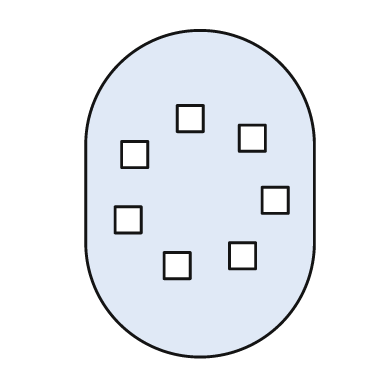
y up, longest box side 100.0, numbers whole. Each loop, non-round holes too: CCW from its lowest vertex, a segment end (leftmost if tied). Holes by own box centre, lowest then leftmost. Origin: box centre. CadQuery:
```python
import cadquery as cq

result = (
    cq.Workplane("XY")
    .moveTo(-35.0, -15.0)
    .threePointArc((0.0, -50.0), (35.0, -15.0))
    .lineTo(35.0, 15.0)
    .threePointArc((0.0, 50.0), (-35.0, 15.0))
    .close()
    .moveTo(-11.0, -26.0)
    .lineTo(-3.0, -26.0)
    .lineTo(-3.0, -18.0)
    .lineTo(-11.0, -18.0)
    .close()
    .moveTo(9.0, -23.0)
    .lineTo(17.0, -23.0)
    .lineTo(17.0, -15.0)
    .lineTo(9.0, -15.0)
    .close()
    .moveTo(-26.0, -12.0)
    .lineTo(-18.0, -12.0)
    .lineTo(-18.0, -4.0)
    .lineTo(-26.0, -4.0)
    .close()
    .moveTo(19.0, -6.0)
    .lineTo(27.0, -6.0)
    .lineTo(27.0, 2.0)
    .lineTo(19.0, 2.0)
    .close()
    .moveTo(-24.0, 8.0)
    .lineTo(-16.0, 8.0)
    .lineTo(-16.0, 16.0)
    .lineTo(-24.0, 16.0)
    .close()
    .moveTo(12.0, 13.0)
    .lineTo(20.0, 13.0)
    .lineTo(20.0, 21.0)
    .lineTo(12.0, 21.0)
    .close()
    .moveTo(-7.0, 19.0)
    .lineTo(1.0, 19.0)
    .lineTo(1.0, 27.0)
    .lineTo(-7.0, 27.0)
    .close()
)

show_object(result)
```